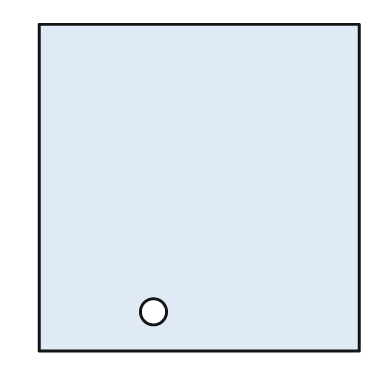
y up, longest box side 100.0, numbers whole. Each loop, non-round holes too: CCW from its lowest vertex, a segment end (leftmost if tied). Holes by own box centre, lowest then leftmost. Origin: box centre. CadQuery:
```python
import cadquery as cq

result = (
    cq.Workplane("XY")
    .moveTo(-49.0, -50.0)
    .lineTo(49.0, -50.0)
    .lineTo(49.0, 50.0)
    .lineTo(-49.0, 50.0)
    .close()
    .moveTo(-14.0, -38.0)
    .circle(4.0)
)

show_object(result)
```